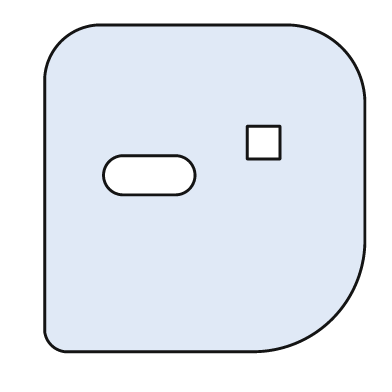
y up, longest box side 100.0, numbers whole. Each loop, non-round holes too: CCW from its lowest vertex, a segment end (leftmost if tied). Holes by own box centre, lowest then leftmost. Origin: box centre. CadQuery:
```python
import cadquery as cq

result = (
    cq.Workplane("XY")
    .moveTo(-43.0, -50.0)
    .lineTo(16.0, -50.0)
    .threePointArc((39.0, -40.0), (49.0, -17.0))
    .lineTo(49.0, 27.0)
    .threePointArc((42.0, 43.0), (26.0, 50.0))
    .lineTo(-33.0, 50.0)
    .threePointArc((-44.0, 45.0), (-49.0, 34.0))
    .lineTo(-49.0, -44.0)
    .threePointArc((-47.0, -48.0), (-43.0, -50.0))
    .close()
    .moveTo(-25.0, -2.0)
    .lineTo(-9.0, -2.0)
    .threePointArc((-3.0, 4.0), (-9.0, 10.0))
    .lineTo(-25.0, 10.0)
    .threePointArc((-31.0, 4.0), (-25.0, -2.0))
    .close()
    .moveTo(13.0, 9.0)
    .lineTo(23.0, 9.0)
    .lineTo(23.0, 19.0)
    .lineTo(13.0, 19.0)
    .close()
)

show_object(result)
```